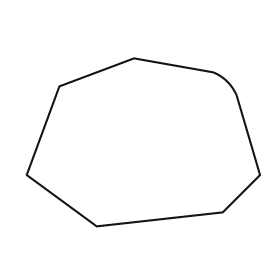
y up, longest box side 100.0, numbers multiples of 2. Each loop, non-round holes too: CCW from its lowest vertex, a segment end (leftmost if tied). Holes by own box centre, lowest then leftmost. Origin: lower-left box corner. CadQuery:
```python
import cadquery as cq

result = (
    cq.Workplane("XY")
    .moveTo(30.0, 0.0)
    .lineTo(84.0, 6.0)
    .lineTo(100.0, 22.0)
    .lineTo(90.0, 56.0)
    .threePointArc((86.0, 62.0), (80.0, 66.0))
    .lineTo(46.0, 72.0)
    .lineTo(14.0, 60.0)
    .lineTo(0.0, 22.0)
    .close()
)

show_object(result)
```